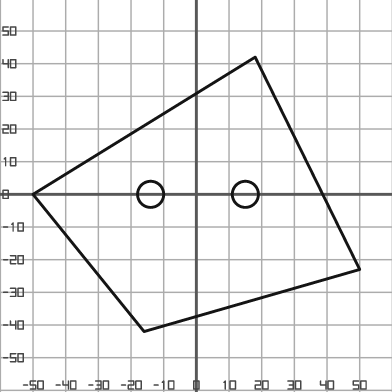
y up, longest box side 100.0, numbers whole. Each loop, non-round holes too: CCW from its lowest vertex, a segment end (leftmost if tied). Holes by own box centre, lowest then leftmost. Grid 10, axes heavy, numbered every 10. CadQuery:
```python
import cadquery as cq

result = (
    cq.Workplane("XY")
    .moveTo(-16.0, -42.0)
    .lineTo(50.0, -23.0)
    .lineTo(18.0, 42.0)
    .lineTo(-50.0, 0.0)
    .close()
    .moveTo(-14.0, 0.0)
    .circle(4.0)
    .moveTo(15.0, 0.0)
    .circle(4.0)
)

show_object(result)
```